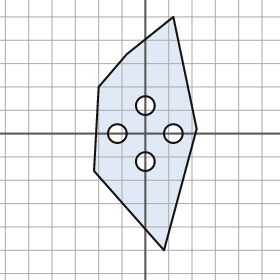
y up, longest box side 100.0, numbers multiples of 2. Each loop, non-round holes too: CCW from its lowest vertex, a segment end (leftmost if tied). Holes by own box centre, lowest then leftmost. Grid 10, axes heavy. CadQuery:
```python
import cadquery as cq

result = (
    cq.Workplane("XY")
    .moveTo(8.0, -50.0)
    .lineTo(22.0, 2.0)
    .lineTo(12.0, 50.0)
    .lineTo(-8.0, 34.0)
    .lineTo(-20.0, 20.0)
    .lineTo(-22.0, -16.0)
    .close()
    .moveTo(0.0, -12.0)
    .circle(4.0)
    .moveTo(-12.0, 0.0)
    .circle(4.0)
    .moveTo(12.0, 0.0)
    .circle(4.0)
    .moveTo(0.0, 12.0)
    .circle(4.0)
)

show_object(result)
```